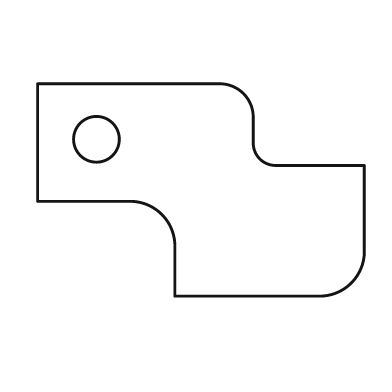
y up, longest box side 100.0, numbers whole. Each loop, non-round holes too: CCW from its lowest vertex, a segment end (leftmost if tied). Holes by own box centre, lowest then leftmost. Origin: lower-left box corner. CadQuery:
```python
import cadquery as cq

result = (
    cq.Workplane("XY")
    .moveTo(42.0, 0.0)
    .lineTo(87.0, 0.0)
    .threePointArc((96.0, 4.0), (100.0, 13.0))
    .lineTo(100.0, 40.0)
    .lineTo(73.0, 40.0)
    .threePointArc((68.0, 42.0), (66.0, 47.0))
    .lineTo(66.0, 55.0)
    .threePointArc((63.0, 62.0), (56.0, 65.0))
    .lineTo(0.0, 65.0)
    .lineTo(0.0, 29.0)
    .lineTo(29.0, 29.0)
    .threePointArc((38.0, 25.0), (42.0, 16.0))
    .close()
    .moveTo(18.0, 48.0)
    .circle(7.0)
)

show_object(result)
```